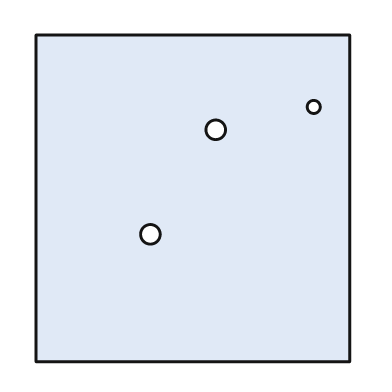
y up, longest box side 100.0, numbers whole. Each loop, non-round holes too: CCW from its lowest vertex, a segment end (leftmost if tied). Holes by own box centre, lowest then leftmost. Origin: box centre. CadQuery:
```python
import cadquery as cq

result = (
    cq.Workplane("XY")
    .moveTo(-48.0, -50.0)
    .lineTo(48.0, -50.0)
    .lineTo(48.0, 50.0)
    .lineTo(-48.0, 50.0)
    .close()
    .moveTo(-13.0, -11.0)
    .circle(3.0)
    .moveTo(7.0, 21.0)
    .circle(3.0)
    .moveTo(37.0, 28.0)
    .circle(2.0)
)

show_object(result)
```